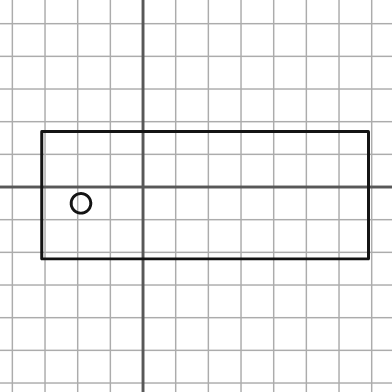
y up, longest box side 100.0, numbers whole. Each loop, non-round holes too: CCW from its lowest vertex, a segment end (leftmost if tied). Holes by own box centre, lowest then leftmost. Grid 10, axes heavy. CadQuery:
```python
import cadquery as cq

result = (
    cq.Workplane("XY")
    .moveTo(-31.0, -22.0)
    .lineTo(69.0, -22.0)
    .lineTo(69.0, 17.0)
    .lineTo(-31.0, 17.0)
    .close()
    .moveTo(-19.0, -5.0)
    .circle(3.0)
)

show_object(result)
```